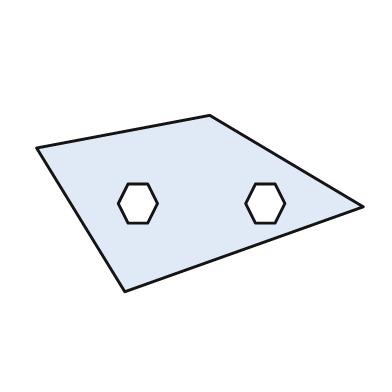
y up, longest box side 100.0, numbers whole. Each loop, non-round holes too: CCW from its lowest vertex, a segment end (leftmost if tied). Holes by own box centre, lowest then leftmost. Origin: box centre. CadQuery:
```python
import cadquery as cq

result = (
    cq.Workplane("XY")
    .moveTo(-23.0, -27.0)
    .lineTo(50.0, -1.0)
    .lineTo(3.0, 27.0)
    .lineTo(-50.0, 17.0)
    .close()
    .moveTo(-22.0, -6.0)
    .lineTo(-16.0, -6.0)
    .lineTo(-13.0, 0.0)
    .lineTo(-16.0, 6.0)
    .lineTo(-22.0, 6.0)
    .lineTo(-25.0, 0.0)
    .close()
    .moveTo(17.0, -6.0)
    .lineTo(23.0, -6.0)
    .lineTo(26.0, 0.0)
    .lineTo(23.0, 6.0)
    .lineTo(17.0, 6.0)
    .lineTo(14.0, 0.0)
    .close()
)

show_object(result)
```